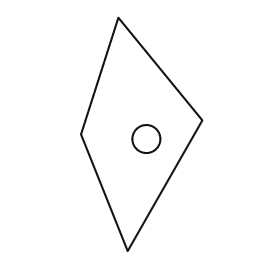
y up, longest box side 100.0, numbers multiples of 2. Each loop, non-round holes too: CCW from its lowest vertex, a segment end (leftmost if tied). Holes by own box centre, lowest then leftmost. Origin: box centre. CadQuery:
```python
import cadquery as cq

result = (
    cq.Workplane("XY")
    .moveTo(-6.0, -50.0)
    .lineTo(26.0, 6.0)
    .lineTo(-10.0, 50.0)
    .lineTo(-26.0, 0.0)
    .close()
    .moveTo(2.0, -2.0)
    .circle(6.0)
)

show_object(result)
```